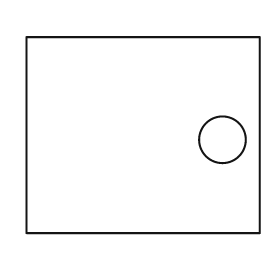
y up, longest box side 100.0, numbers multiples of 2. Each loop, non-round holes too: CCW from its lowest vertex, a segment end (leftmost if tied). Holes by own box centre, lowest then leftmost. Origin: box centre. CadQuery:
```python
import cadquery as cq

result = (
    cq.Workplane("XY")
    .moveTo(-50.0, -42.0)
    .lineTo(50.0, -42.0)
    .lineTo(50.0, 42.0)
    .lineTo(-50.0, 42.0)
    .close()
    .moveTo(34.0, -2.0)
    .circle(10.0)
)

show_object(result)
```